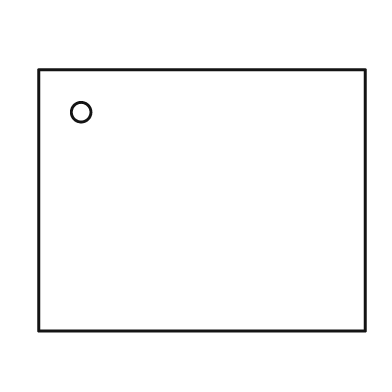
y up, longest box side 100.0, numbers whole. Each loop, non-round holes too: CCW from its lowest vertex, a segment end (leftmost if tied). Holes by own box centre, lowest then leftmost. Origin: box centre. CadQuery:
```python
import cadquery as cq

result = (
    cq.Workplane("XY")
    .moveTo(-50.0, -40.0)
    .lineTo(50.0, -40.0)
    .lineTo(50.0, 40.0)
    .lineTo(-50.0, 40.0)
    .close()
    .moveTo(-37.0, 27.0)
    .circle(3.0)
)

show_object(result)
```